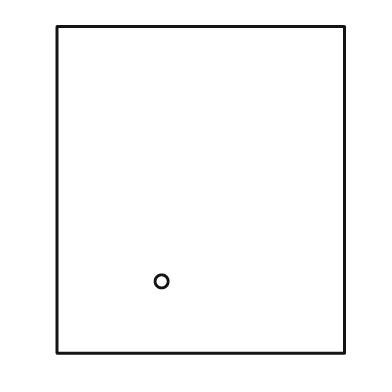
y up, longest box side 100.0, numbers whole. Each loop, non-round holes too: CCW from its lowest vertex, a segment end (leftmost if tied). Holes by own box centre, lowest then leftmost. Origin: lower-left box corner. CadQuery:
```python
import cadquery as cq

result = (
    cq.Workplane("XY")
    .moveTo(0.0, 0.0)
    .lineTo(88.0, 0.0)
    .lineTo(88.0, 100.0)
    .lineTo(0.0, 100.0)
    .close()
    .moveTo(32.0, 22.0)
    .circle(2.0)
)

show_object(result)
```